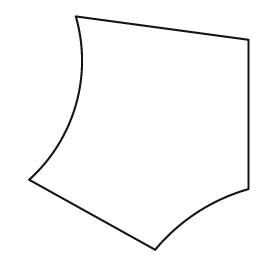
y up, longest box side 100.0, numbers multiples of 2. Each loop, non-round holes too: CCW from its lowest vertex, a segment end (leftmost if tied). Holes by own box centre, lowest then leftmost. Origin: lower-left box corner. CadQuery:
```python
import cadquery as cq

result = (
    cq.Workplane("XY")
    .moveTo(54.0, 0.0)
    .threePointArc((72.0, 16.0), (94.0, 26.0))
    .lineTo(94.0, 90.0)
    .lineTo(20.0, 100.0)
    .threePointArc((20.0, 62.0), (0.0, 30.0))
    .close()
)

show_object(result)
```